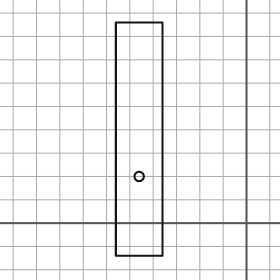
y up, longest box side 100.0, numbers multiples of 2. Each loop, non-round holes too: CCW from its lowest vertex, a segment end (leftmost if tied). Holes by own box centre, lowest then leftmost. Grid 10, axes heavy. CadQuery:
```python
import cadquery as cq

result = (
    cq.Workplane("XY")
    .moveTo(-56.0, -14.0)
    .lineTo(-36.0, -14.0)
    .lineTo(-36.0, 86.0)
    .lineTo(-56.0, 86.0)
    .close()
    .moveTo(-46.0, 20.0)
    .circle(2.0)
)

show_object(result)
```